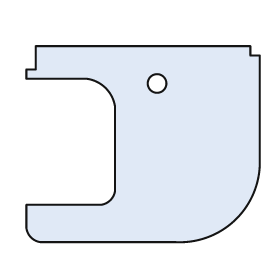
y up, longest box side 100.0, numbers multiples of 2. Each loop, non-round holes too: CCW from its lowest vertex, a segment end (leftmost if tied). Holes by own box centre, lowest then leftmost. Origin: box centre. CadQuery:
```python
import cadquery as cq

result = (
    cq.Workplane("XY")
    .moveTo(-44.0, -42.0)
    .lineTo(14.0, -42.0)
    .threePointArc((40.0, -32.0), (50.0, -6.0))
    .lineTo(50.0, 38.0)
    .lineTo(46.0, 38.0)
    .lineTo(46.0, 42.0)
    .lineTo(-46.0, 42.0)
    .lineTo(-46.0, 32.0)
    .lineTo(-50.0, 32.0)
    .lineTo(-50.0, 28.0)
    .lineTo(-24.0, 28.0)
    .threePointArc((-16.0, 24.0), (-12.0, 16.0))
    .lineTo(-12.0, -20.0)
    .threePointArc((-14.0, -24.0), (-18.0, -26.0))
    .lineTo(-50.0, -26.0)
    .lineTo(-50.0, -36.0)
    .threePointArc((-48.0, -40.0), (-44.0, -42.0))
    .close()
    .moveTo(6.0, 26.0)
    .circle(4.0)
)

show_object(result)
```